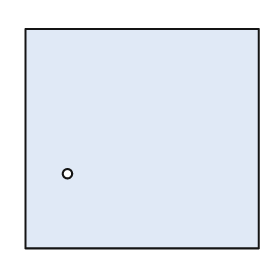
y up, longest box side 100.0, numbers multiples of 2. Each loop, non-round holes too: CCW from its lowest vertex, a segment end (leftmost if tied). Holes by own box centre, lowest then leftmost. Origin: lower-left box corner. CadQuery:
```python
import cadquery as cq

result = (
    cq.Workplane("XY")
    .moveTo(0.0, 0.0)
    .lineTo(100.0, 0.0)
    .lineTo(100.0, 94.0)
    .lineTo(0.0, 94.0)
    .close()
    .moveTo(18.0, 32.0)
    .circle(2.0)
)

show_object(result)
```